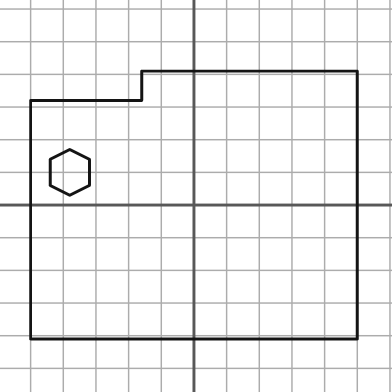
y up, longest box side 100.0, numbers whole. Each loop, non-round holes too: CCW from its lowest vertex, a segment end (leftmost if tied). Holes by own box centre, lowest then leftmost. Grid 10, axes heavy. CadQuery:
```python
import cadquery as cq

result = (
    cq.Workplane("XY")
    .moveTo(-50.0, -41.0)
    .lineTo(50.0, -41.0)
    .lineTo(50.0, 41.0)
    .lineTo(-16.0, 41.0)
    .lineTo(-16.0, 32.0)
    .lineTo(-50.0, 32.0)
    .close()
    .moveTo(-38.0, 3.0)
    .lineTo(-32.0, 6.0)
    .lineTo(-32.0, 14.0)
    .lineTo(-38.0, 17.0)
    .lineTo(-44.0, 14.0)
    .lineTo(-44.0, 6.0)
    .close()
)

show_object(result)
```